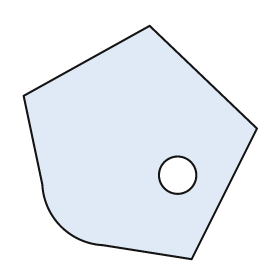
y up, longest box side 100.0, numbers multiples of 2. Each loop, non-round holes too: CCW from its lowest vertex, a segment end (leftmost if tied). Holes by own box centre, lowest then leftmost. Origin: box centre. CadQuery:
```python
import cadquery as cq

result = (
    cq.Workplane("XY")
    .moveTo(22.0, -50.0)
    .lineTo(50.0, 6.0)
    .lineTo(4.0, 50.0)
    .lineTo(-50.0, 20.0)
    .lineTo(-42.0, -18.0)
    .threePointArc((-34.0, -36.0), (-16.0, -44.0))
    .close()
    .moveTo(16.0, -14.0)
    .circle(8.0)
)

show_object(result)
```